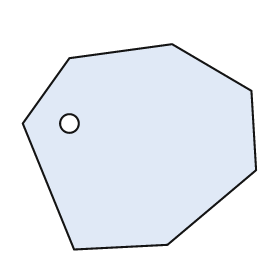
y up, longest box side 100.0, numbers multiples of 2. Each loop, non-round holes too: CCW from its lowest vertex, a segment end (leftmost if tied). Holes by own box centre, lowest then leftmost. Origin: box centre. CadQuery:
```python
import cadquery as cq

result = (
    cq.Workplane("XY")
    .moveTo(-28.0, -44.0)
    .lineTo(12.0, -42.0)
    .lineTo(50.0, -10.0)
    .lineTo(48.0, 24.0)
    .lineTo(14.0, 44.0)
    .lineTo(-30.0, 38.0)
    .lineTo(-50.0, 10.0)
    .close()
    .moveTo(-30.0, 10.0)
    .circle(4.0)
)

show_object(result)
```